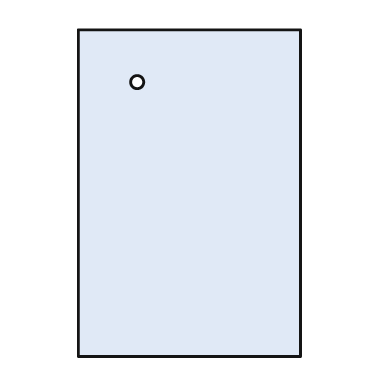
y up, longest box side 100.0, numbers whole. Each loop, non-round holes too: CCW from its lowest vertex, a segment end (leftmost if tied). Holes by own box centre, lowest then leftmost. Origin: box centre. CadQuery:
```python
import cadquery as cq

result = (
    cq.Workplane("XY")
    .moveTo(-34.0, -50.0)
    .lineTo(34.0, -50.0)
    .lineTo(34.0, 50.0)
    .lineTo(-34.0, 50.0)
    .close()
    .moveTo(-16.0, 34.0)
    .circle(2.0)
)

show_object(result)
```